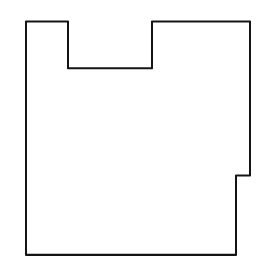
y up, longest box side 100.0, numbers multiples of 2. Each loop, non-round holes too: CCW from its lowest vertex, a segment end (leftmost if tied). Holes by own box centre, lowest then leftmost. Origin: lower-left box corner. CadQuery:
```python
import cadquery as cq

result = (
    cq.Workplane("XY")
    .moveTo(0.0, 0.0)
    .lineTo(90.0, 0.0)
    .lineTo(90.0, 34.0)
    .lineTo(96.0, 34.0)
    .lineTo(96.0, 100.0)
    .lineTo(54.0, 100.0)
    .lineTo(54.0, 80.0)
    .lineTo(18.0, 80.0)
    .lineTo(18.0, 100.0)
    .lineTo(0.0, 100.0)
    .close()
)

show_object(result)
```